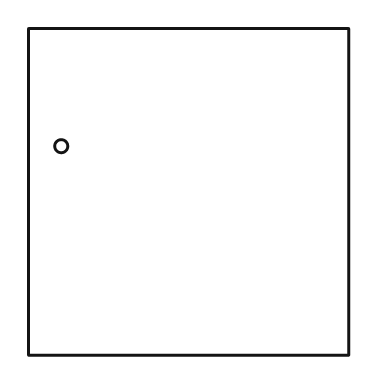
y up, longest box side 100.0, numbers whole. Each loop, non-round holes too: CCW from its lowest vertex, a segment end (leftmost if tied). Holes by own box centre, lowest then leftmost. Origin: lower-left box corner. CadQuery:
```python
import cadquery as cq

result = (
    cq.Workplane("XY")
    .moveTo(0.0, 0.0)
    .lineTo(98.0, 0.0)
    .lineTo(98.0, 100.0)
    .lineTo(0.0, 100.0)
    .close()
    .moveTo(10.0, 64.0)
    .circle(2.0)
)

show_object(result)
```